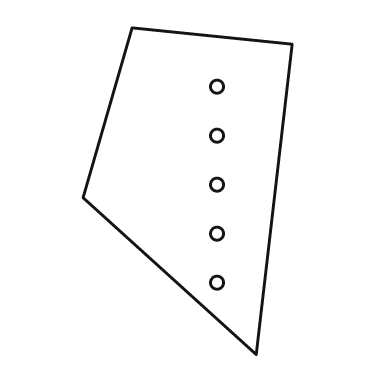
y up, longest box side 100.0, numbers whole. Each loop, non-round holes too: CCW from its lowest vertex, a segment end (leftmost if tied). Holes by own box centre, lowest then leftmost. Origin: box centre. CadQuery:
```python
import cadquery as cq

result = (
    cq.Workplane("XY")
    .moveTo(21.0, -50.0)
    .lineTo(32.0, 45.0)
    .lineTo(-17.0, 50.0)
    .lineTo(-32.0, -2.0)
    .close()
    .moveTo(9.0, -28.0)
    .circle(2.0)
    .moveTo(9.0, -13.0)
    .circle(2.0)
    .moveTo(9.0, 2.0)
    .circle(2.0)
    .moveTo(9.0, 17.0)
    .circle(2.0)
    .moveTo(9.0, 32.0)
    .circle(2.0)
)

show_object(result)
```